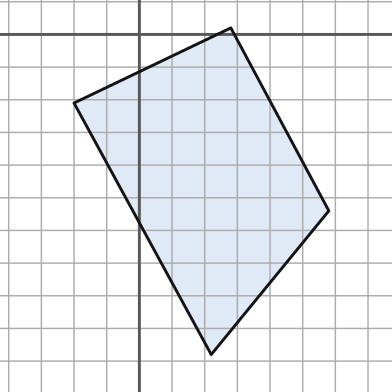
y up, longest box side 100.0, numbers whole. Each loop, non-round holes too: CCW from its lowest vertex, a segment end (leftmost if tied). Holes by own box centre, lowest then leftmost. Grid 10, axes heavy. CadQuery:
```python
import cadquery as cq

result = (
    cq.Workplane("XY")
    .moveTo(22.0, -98.0)
    .lineTo(58.0, -54.0)
    .lineTo(28.0, 2.0)
    .lineTo(-20.0, -21.0)
    .close()
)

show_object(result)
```